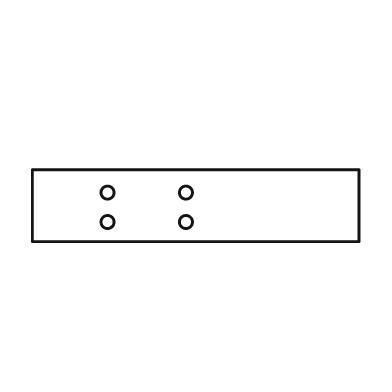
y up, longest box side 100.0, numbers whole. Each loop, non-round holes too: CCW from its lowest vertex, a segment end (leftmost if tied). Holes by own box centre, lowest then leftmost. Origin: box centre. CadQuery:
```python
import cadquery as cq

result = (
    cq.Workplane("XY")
    .moveTo(-50.0, -11.0)
    .lineTo(50.0, -11.0)
    .lineTo(50.0, 11.0)
    .lineTo(-50.0, 11.0)
    .close()
    .moveTo(-27.0, -5.0)
    .circle(2.0)
    .moveTo(-3.0, -5.0)
    .circle(2.0)
    .moveTo(-27.0, 4.0)
    .circle(2.0)
    .moveTo(-3.0, 4.0)
    .circle(2.0)
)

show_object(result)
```